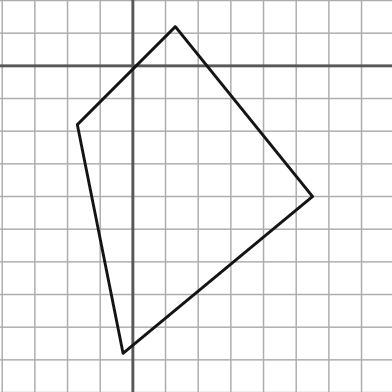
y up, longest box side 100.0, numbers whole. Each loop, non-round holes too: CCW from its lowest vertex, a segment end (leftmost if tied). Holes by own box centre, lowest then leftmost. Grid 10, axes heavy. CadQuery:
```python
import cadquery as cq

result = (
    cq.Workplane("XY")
    .moveTo(-3.0, -88.0)
    .lineTo(55.0, -40.0)
    .lineTo(13.0, 12.0)
    .lineTo(-17.0, -18.0)
    .close()
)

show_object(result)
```